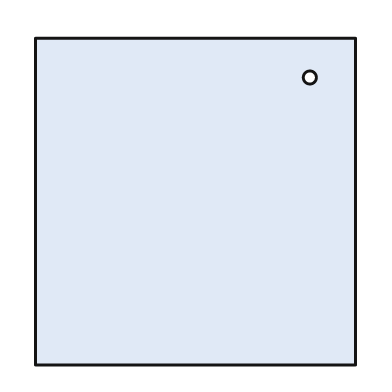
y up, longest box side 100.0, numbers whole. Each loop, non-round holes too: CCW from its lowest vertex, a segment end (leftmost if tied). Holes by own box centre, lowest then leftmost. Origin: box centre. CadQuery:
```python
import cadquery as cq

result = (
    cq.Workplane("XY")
    .moveTo(-49.0, -50.0)
    .lineTo(49.0, -50.0)
    .lineTo(49.0, 50.0)
    .lineTo(-49.0, 50.0)
    .close()
    .moveTo(35.0, 38.0)
    .circle(2.0)
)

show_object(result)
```